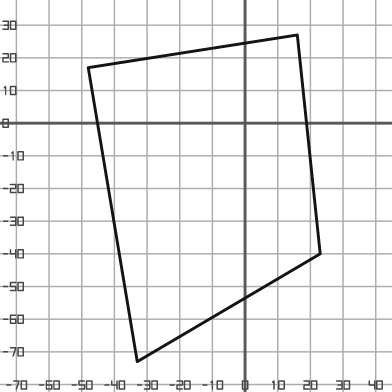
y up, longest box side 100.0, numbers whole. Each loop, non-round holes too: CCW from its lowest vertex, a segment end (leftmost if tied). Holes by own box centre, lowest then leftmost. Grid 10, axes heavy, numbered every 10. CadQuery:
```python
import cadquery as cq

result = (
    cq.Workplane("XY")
    .moveTo(-33.0, -73.0)
    .lineTo(23.0, -40.0)
    .lineTo(16.0, 27.0)
    .lineTo(-48.0, 17.0)
    .close()
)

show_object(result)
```